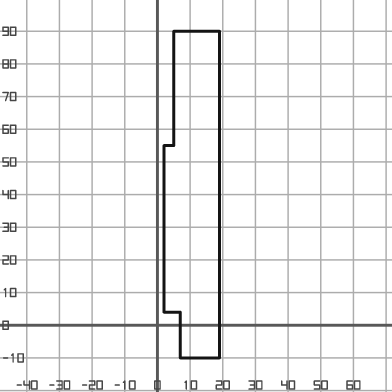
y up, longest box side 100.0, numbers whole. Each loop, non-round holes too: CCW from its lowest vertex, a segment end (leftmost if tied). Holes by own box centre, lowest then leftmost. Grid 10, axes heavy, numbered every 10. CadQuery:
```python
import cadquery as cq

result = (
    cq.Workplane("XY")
    .moveTo(7.0, -10.0)
    .lineTo(19.0, -10.0)
    .lineTo(19.0, 90.0)
    .lineTo(5.0, 90.0)
    .lineTo(5.0, 55.0)
    .lineTo(2.0, 55.0)
    .lineTo(2.0, 4.0)
    .lineTo(7.0, 4.0)
    .close()
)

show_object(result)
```